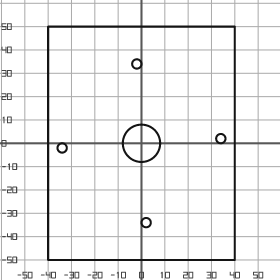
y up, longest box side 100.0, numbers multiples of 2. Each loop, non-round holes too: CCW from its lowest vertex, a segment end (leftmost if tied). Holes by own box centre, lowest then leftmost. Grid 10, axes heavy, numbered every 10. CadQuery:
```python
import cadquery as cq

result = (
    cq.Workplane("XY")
    .moveTo(-40.0, -50.0)
    .lineTo(40.0, -50.0)
    .lineTo(40.0, 50.0)
    .lineTo(-40.0, 50.0)
    .close()
    .moveTo(2.0, -34.0)
    .circle(2.0)
    .moveTo(-34.0, -2.0)
    .circle(2.0)
    .moveTo(0.0, 0.0)
    .circle(8.0)
    .moveTo(34.0, 2.0)
    .circle(2.0)
    .moveTo(-2.0, 34.0)
    .circle(2.0)
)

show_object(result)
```